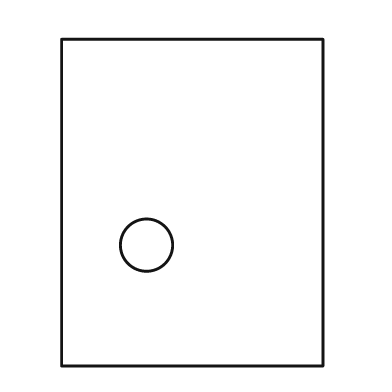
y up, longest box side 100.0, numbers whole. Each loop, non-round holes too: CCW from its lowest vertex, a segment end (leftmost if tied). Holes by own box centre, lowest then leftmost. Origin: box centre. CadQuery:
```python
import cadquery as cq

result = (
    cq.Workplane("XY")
    .moveTo(-40.0, -50.0)
    .lineTo(40.0, -50.0)
    .lineTo(40.0, 50.0)
    .lineTo(-40.0, 50.0)
    .close()
    .moveTo(-14.0, -13.0)
    .circle(8.0)
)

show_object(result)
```